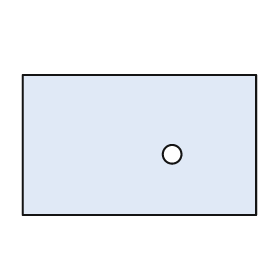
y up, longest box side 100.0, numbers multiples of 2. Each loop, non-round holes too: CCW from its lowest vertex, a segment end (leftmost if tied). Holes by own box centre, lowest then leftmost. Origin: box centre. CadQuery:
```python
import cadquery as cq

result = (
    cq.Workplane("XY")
    .moveTo(-50.0, -30.0)
    .lineTo(50.0, -30.0)
    .lineTo(50.0, 30.0)
    .lineTo(-50.0, 30.0)
    .close()
    .moveTo(14.0, -4.0)
    .circle(4.0)
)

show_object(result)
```